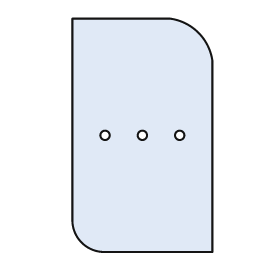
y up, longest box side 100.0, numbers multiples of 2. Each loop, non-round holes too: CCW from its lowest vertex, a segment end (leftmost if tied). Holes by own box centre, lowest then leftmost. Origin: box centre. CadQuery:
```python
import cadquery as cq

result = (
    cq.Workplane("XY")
    .moveTo(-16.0, -50.0)
    .lineTo(30.0, -50.0)
    .lineTo(30.0, 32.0)
    .threePointArc((24.0, 44.0), (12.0, 50.0))
    .lineTo(-30.0, 50.0)
    .lineTo(-30.0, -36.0)
    .threePointArc((-26.0, -46.0), (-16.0, -50.0))
    .close()
    .moveTo(-16.0, 0.0)
    .circle(2.0)
    .moveTo(0.0, 0.0)
    .circle(2.0)
    .moveTo(16.0, 0.0)
    .circle(2.0)
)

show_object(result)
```